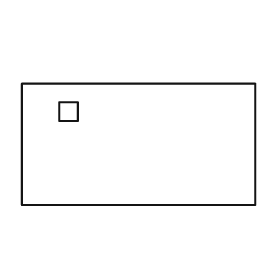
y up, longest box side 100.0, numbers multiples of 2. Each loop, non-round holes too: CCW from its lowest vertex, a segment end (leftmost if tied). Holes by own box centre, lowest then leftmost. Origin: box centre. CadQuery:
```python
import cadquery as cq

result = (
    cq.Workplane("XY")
    .moveTo(-50.0, -26.0)
    .lineTo(50.0, -26.0)
    .lineTo(50.0, 26.0)
    .lineTo(-50.0, 26.0)
    .close()
    .moveTo(-34.0, 10.0)
    .lineTo(-26.0, 10.0)
    .lineTo(-26.0, 18.0)
    .lineTo(-34.0, 18.0)
    .close()
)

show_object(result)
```